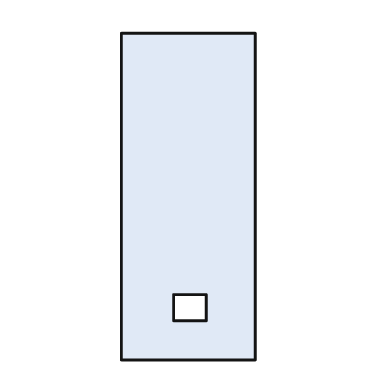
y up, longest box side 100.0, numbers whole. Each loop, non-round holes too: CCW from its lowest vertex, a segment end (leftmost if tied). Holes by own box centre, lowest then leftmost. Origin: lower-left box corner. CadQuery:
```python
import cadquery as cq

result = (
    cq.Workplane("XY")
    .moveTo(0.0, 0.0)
    .lineTo(41.0, 0.0)
    .lineTo(41.0, 100.0)
    .lineTo(0.0, 100.0)
    .close()
    .moveTo(16.0, 12.0)
    .lineTo(26.0, 12.0)
    .lineTo(26.0, 20.0)
    .lineTo(16.0, 20.0)
    .close()
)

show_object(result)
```